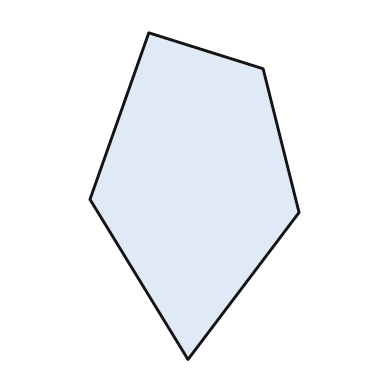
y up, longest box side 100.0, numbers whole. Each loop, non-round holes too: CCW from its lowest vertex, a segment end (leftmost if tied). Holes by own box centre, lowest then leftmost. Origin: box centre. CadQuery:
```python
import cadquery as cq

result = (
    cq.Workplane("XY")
    .moveTo(-2.0, -50.0)
    .lineTo(32.0, -5.0)
    .lineTo(21.0, 39.0)
    .lineTo(-14.0, 50.0)
    .lineTo(-32.0, -1.0)
    .close()
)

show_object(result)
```